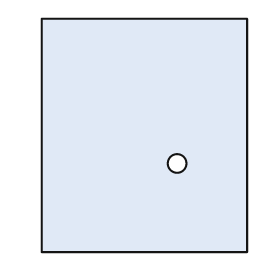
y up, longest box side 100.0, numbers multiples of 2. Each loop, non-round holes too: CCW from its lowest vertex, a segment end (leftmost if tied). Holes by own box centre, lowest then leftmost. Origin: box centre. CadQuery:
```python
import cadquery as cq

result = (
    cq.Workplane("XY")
    .moveTo(-44.0, -50.0)
    .lineTo(44.0, -50.0)
    .lineTo(44.0, 50.0)
    .lineTo(-44.0, 50.0)
    .close()
    .moveTo(14.0, -12.0)
    .circle(4.0)
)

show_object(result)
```